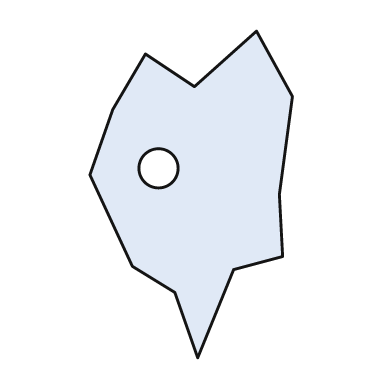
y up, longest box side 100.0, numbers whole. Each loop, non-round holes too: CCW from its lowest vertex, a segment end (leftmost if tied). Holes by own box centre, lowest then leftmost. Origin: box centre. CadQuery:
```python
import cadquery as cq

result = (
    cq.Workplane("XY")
    .moveTo(2.0, -50.0)
    .lineTo(13.0, -23.0)
    .lineTo(28.0, -19.0)
    .lineTo(27.0, 0.0)
    .lineTo(31.0, 30.0)
    .lineTo(20.0, 50.0)
    .lineTo(1.0, 33.0)
    .lineTo(-14.0, 43.0)
    .lineTo(-24.0, 26.0)
    .lineTo(-31.0, 6.0)
    .lineTo(-18.0, -22.0)
    .lineTo(-5.0, -30.0)
    .close()
    .moveTo(-10.0, 8.0)
    .circle(6.0)
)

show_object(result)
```